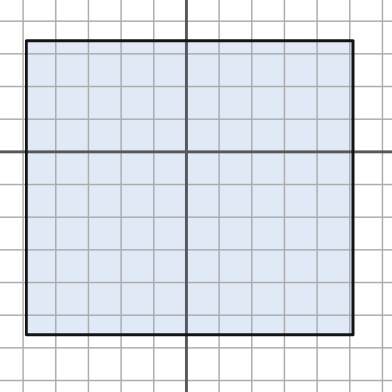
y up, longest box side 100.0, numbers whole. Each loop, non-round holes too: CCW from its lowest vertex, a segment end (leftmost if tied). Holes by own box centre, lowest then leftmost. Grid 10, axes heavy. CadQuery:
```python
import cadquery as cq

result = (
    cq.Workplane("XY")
    .moveTo(-49.0, -56.0)
    .lineTo(51.0, -56.0)
    .lineTo(51.0, 34.0)
    .lineTo(-49.0, 34.0)
    .close()
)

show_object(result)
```